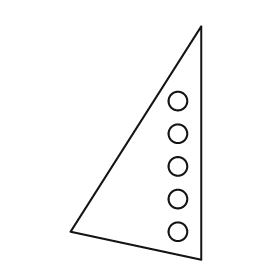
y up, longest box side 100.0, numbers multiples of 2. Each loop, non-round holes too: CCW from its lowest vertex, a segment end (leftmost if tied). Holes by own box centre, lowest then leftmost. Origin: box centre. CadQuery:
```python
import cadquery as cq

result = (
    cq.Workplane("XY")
    .moveTo(28.0, -50.0)
    .lineTo(28.0, 50.0)
    .lineTo(-28.0, -38.0)
    .close()
    .moveTo(18.0, -38.0)
    .circle(4.0)
    .moveTo(18.0, -24.0)
    .circle(4.0)
    .moveTo(18.0, -10.0)
    .circle(4.0)
    .moveTo(18.0, 4.0)
    .circle(4.0)
    .moveTo(18.0, 18.0)
    .circle(4.0)
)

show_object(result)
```